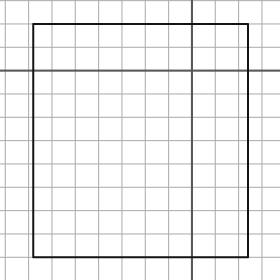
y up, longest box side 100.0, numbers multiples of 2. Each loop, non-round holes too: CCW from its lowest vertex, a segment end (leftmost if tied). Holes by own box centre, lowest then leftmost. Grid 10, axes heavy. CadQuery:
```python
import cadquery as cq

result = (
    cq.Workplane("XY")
    .moveTo(-68.0, -80.0)
    .lineTo(24.0, -80.0)
    .lineTo(24.0, 20.0)
    .lineTo(-68.0, 20.0)
    .close()
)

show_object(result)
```